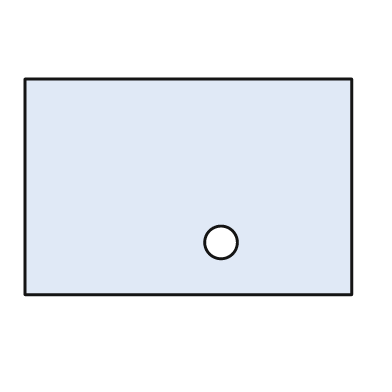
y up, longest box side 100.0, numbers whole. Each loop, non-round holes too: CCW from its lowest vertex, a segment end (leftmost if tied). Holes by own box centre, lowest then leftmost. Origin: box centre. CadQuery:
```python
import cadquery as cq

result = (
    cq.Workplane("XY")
    .moveTo(-50.0, -33.0)
    .lineTo(50.0, -33.0)
    .lineTo(50.0, 33.0)
    .lineTo(-50.0, 33.0)
    .close()
    .moveTo(10.0, -17.0)
    .circle(5.0)
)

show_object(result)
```